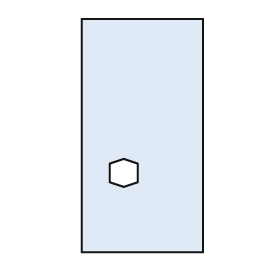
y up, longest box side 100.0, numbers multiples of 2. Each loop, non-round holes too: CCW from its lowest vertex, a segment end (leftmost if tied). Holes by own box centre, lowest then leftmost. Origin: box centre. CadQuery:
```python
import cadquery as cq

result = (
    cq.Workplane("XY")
    .moveTo(-26.0, -50.0)
    .lineTo(26.0, -50.0)
    .lineTo(26.0, 50.0)
    .lineTo(-26.0, 50.0)
    .close()
    .moveTo(-8.0, -22.0)
    .lineTo(-2.0, -20.0)
    .lineTo(-2.0, -12.0)
    .lineTo(-8.0, -10.0)
    .lineTo(-14.0, -12.0)
    .lineTo(-14.0, -20.0)
    .close()
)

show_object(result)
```